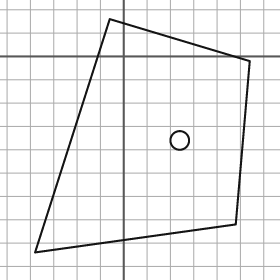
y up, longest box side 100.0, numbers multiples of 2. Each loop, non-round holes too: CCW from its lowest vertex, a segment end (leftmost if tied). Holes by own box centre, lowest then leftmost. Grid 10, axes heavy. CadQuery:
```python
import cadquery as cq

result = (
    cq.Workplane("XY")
    .moveTo(-38.0, -84.0)
    .lineTo(48.0, -72.0)
    .lineTo(54.0, -2.0)
    .lineTo(-6.0, 16.0)
    .close()
    .moveTo(24.0, -36.0)
    .circle(4.0)
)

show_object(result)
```